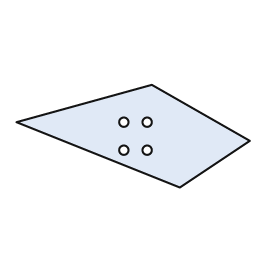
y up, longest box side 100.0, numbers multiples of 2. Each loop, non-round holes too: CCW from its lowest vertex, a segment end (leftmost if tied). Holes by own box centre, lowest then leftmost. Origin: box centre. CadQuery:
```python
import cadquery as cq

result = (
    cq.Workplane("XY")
    .moveTo(20.0, -22.0)
    .lineTo(50.0, -2.0)
    .lineTo(8.0, 22.0)
    .lineTo(-50.0, 6.0)
    .close()
    .moveTo(-4.0, -6.0)
    .circle(2.0)
    .moveTo(6.0, -6.0)
    .circle(2.0)
    .moveTo(-4.0, 6.0)
    .circle(2.0)
    .moveTo(6.0, 6.0)
    .circle(2.0)
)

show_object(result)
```